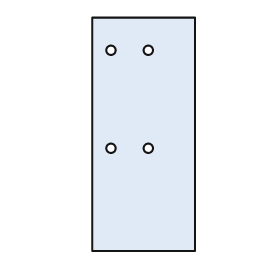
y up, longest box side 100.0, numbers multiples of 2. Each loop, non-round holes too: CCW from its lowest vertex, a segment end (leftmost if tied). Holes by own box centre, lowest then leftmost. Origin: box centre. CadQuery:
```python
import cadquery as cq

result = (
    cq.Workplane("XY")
    .moveTo(-22.0, -50.0)
    .lineTo(22.0, -50.0)
    .lineTo(22.0, 50.0)
    .lineTo(-22.0, 50.0)
    .close()
    .moveTo(-14.0, -6.0)
    .circle(2.0)
    .moveTo(2.0, -6.0)
    .circle(2.0)
    .moveTo(-14.0, 36.0)
    .circle(2.0)
    .moveTo(2.0, 36.0)
    .circle(2.0)
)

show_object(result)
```